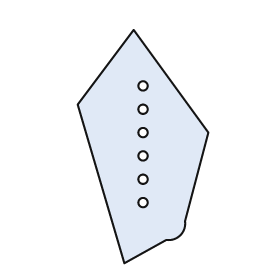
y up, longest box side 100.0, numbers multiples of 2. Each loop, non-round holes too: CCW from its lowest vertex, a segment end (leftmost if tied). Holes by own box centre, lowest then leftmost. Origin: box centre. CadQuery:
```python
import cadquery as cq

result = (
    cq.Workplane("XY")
    .moveTo(-8.0, -50.0)
    .lineTo(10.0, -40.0)
    .threePointArc((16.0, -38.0), (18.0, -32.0))
    .lineTo(28.0, 6.0)
    .lineTo(-4.0, 50.0)
    .lineTo(-28.0, 18.0)
    .close()
    .moveTo(0.0, -24.0)
    .circle(2.0)
    .moveTo(0.0, -14.0)
    .circle(2.0)
    .moveTo(0.0, -4.0)
    .circle(2.0)
    .moveTo(0.0, 6.0)
    .circle(2.0)
    .moveTo(0.0, 16.0)
    .circle(2.0)
    .moveTo(0.0, 26.0)
    .circle(2.0)
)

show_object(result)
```